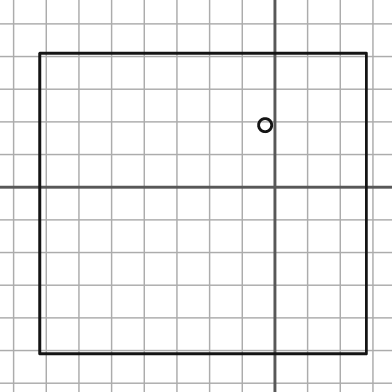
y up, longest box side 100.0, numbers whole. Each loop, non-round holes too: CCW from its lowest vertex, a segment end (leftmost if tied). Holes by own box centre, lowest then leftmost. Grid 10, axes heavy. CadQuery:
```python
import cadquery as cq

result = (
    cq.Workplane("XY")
    .moveTo(-72.0, -51.0)
    .lineTo(28.0, -51.0)
    .lineTo(28.0, 41.0)
    .lineTo(-72.0, 41.0)
    .close()
    .moveTo(-3.0, 19.0)
    .circle(2.0)
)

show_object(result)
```